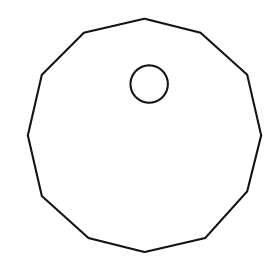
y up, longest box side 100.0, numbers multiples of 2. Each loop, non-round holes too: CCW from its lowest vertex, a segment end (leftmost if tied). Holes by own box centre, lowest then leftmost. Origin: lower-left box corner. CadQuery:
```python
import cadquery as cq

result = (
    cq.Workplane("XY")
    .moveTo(50.0, 0.0)
    .lineTo(76.0, 6.0)
    .lineTo(94.0, 26.0)
    .lineTo(100.0, 50.0)
    .lineTo(94.0, 76.0)
    .lineTo(74.0, 94.0)
    .lineTo(50.0, 100.0)
    .lineTo(24.0, 94.0)
    .lineTo(6.0, 76.0)
    .lineTo(0.0, 50.0)
    .lineTo(6.0, 24.0)
    .lineTo(26.0, 6.0)
    .close()
    .moveTo(52.0, 72.0)
    .circle(8.0)
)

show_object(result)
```